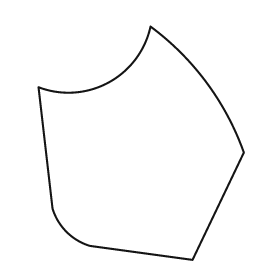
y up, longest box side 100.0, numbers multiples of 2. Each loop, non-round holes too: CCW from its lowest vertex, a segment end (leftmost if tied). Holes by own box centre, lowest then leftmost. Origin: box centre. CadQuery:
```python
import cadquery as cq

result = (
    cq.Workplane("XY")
    .moveTo(22.0, -50.0)
    .lineTo(44.0, -4.0)
    .threePointArc((28.0, 26.0), (4.0, 50.0))
    .threePointArc((-14.0, 26.0), (-44.0, 24.0))
    .lineTo(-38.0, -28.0)
    .threePointArc((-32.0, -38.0), (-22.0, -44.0))
    .close()
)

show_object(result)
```